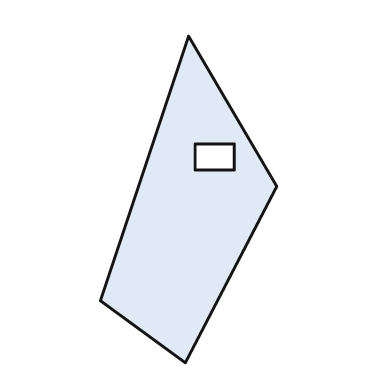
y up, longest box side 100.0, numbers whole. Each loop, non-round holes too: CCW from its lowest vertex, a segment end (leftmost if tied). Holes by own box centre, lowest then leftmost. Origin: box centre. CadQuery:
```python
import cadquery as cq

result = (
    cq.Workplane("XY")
    .moveTo(-1.0, -50.0)
    .lineTo(27.0, 4.0)
    .lineTo(0.0, 50.0)
    .lineTo(-27.0, -31.0)
    .close()
    .moveTo(2.0, 9.0)
    .lineTo(14.0, 9.0)
    .lineTo(14.0, 17.0)
    .lineTo(2.0, 17.0)
    .close()
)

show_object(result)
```